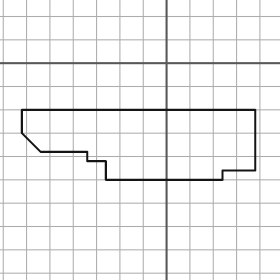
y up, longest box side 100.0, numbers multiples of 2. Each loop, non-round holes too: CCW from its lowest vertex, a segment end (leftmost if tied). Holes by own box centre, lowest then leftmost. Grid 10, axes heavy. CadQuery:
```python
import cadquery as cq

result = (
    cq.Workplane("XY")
    .moveTo(-26.0, -50.0)
    .lineTo(24.0, -50.0)
    .lineTo(24.0, -46.0)
    .lineTo(38.0, -46.0)
    .lineTo(38.0, -20.0)
    .lineTo(-62.0, -20.0)
    .lineTo(-62.0, -30.0)
    .lineTo(-54.0, -38.0)
    .lineTo(-34.0, -38.0)
    .lineTo(-34.0, -42.0)
    .lineTo(-26.0, -42.0)
    .close()
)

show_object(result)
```